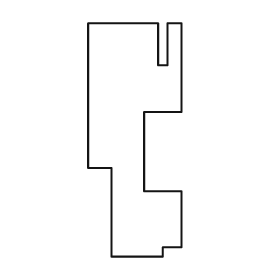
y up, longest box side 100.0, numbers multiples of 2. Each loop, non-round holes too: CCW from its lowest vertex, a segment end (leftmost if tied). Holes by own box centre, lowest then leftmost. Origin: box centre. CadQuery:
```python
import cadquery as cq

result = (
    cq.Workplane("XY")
    .moveTo(-10.0, -50.0)
    .lineTo(12.0, -50.0)
    .lineTo(12.0, -46.0)
    .lineTo(20.0, -46.0)
    .lineTo(20.0, -22.0)
    .lineTo(4.0, -22.0)
    .lineTo(4.0, 12.0)
    .lineTo(20.0, 12.0)
    .lineTo(20.0, 50.0)
    .lineTo(14.0, 50.0)
    .lineTo(14.0, 32.0)
    .lineTo(10.0, 32.0)
    .lineTo(10.0, 50.0)
    .lineTo(-20.0, 50.0)
    .lineTo(-20.0, -12.0)
    .lineTo(-10.0, -12.0)
    .close()
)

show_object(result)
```